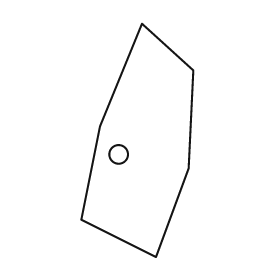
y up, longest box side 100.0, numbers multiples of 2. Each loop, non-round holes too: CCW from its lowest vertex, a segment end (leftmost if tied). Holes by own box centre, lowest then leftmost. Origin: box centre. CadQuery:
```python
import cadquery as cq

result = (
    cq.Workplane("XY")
    .moveTo(8.0, -50.0)
    .lineTo(22.0, -12.0)
    .lineTo(24.0, 30.0)
    .lineTo(2.0, 50.0)
    .lineTo(-16.0, 6.0)
    .lineTo(-24.0, -34.0)
    .close()
    .moveTo(-8.0, -6.0)
    .circle(4.0)
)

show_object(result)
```